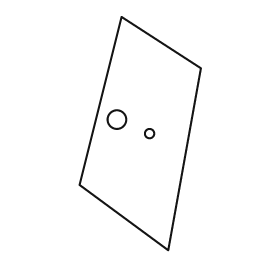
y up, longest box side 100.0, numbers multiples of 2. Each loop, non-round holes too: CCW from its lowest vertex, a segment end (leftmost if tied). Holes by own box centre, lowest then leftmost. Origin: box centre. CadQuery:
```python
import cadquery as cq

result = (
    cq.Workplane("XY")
    .moveTo(12.0, -50.0)
    .lineTo(26.0, 28.0)
    .lineTo(-8.0, 50.0)
    .lineTo(-26.0, -22.0)
    .close()
    .moveTo(4.0, 0.0)
    .circle(2.0)
    .moveTo(-10.0, 6.0)
    .circle(4.0)
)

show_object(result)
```